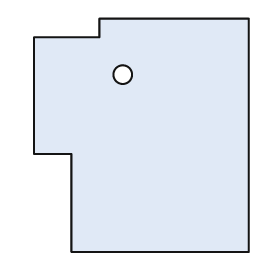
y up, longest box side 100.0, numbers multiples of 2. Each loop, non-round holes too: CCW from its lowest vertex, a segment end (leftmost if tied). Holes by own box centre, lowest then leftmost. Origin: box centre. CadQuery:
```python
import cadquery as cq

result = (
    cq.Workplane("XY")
    .moveTo(-30.0, -50.0)
    .lineTo(46.0, -50.0)
    .lineTo(46.0, 50.0)
    .lineTo(-18.0, 50.0)
    .lineTo(-18.0, 42.0)
    .lineTo(-46.0, 42.0)
    .lineTo(-46.0, -8.0)
    .lineTo(-30.0, -8.0)
    .close()
    .moveTo(-8.0, 26.0)
    .circle(4.0)
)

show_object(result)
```